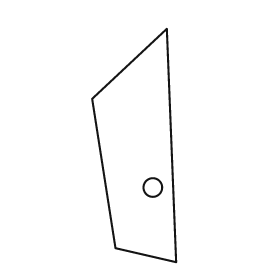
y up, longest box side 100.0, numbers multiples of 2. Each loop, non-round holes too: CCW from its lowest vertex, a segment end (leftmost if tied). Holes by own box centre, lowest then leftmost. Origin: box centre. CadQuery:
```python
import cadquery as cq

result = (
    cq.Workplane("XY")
    .moveTo(18.0, -50.0)
    .lineTo(14.0, 50.0)
    .lineTo(-18.0, 20.0)
    .lineTo(-8.0, -44.0)
    .close()
    .moveTo(8.0, -18.0)
    .circle(4.0)
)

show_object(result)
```